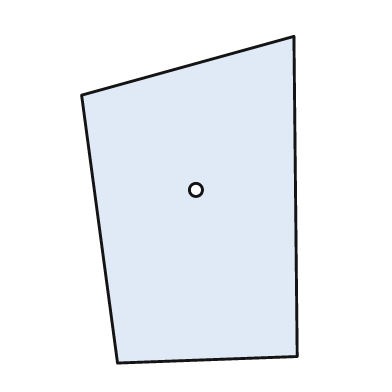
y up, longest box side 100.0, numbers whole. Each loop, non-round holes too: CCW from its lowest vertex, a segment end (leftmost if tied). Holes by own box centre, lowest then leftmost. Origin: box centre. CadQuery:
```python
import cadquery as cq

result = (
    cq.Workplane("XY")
    .moveTo(-22.0, -50.0)
    .lineTo(33.0, -48.0)
    .lineTo(32.0, 50.0)
    .lineTo(-33.0, 32.0)
    .close()
    .moveTo(2.0, 3.0)
    .circle(2.0)
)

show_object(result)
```